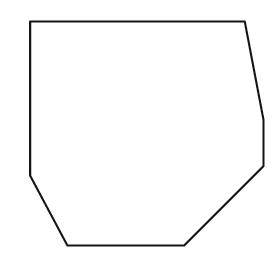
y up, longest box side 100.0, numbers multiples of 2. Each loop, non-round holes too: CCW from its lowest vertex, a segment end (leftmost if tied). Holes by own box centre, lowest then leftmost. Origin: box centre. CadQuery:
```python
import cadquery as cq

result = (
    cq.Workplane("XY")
    .moveTo(-34.0, -48.0)
    .lineTo(16.0, -48.0)
    .lineTo(50.0, -14.0)
    .lineTo(50.0, 6.0)
    .lineTo(42.0, 48.0)
    .lineTo(-50.0, 48.0)
    .lineTo(-50.0, -18.0)
    .close()
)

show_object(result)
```